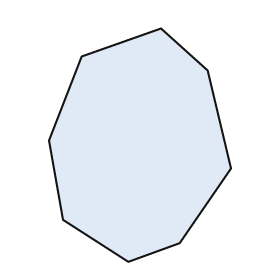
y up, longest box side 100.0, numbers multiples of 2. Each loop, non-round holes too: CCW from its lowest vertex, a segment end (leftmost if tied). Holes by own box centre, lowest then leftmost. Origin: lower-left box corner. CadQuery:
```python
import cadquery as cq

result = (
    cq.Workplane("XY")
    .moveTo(34.0, 0.0)
    .lineTo(56.0, 8.0)
    .lineTo(78.0, 40.0)
    .lineTo(68.0, 82.0)
    .lineTo(48.0, 100.0)
    .lineTo(14.0, 88.0)
    .lineTo(0.0, 52.0)
    .lineTo(6.0, 18.0)
    .close()
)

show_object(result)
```